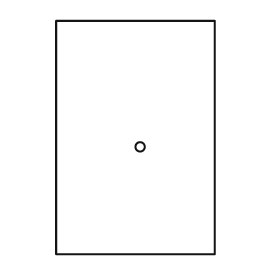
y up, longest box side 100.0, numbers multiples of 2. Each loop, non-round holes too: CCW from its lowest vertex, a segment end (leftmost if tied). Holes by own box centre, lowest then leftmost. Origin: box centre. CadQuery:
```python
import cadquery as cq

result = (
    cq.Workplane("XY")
    .moveTo(-34.0, -50.0)
    .lineTo(34.0, -50.0)
    .lineTo(34.0, 50.0)
    .lineTo(-34.0, 50.0)
    .close()
    .moveTo(2.0, -4.0)
    .circle(2.0)
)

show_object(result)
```